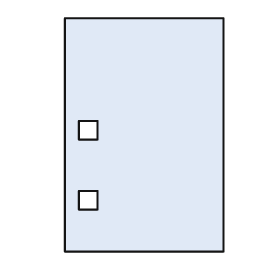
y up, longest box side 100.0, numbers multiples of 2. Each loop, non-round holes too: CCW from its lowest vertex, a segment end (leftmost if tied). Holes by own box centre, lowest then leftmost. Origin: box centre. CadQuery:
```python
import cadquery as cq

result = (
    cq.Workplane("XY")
    .moveTo(-34.0, -50.0)
    .lineTo(34.0, -50.0)
    .lineTo(34.0, 50.0)
    .lineTo(-34.0, 50.0)
    .close()
    .moveTo(-28.0, -32.0)
    .lineTo(-20.0, -32.0)
    .lineTo(-20.0, -24.0)
    .lineTo(-28.0, -24.0)
    .close()
    .moveTo(-28.0, -2.0)
    .lineTo(-20.0, -2.0)
    .lineTo(-20.0, 6.0)
    .lineTo(-28.0, 6.0)
    .close()
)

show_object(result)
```